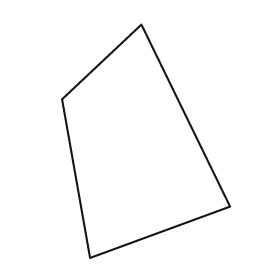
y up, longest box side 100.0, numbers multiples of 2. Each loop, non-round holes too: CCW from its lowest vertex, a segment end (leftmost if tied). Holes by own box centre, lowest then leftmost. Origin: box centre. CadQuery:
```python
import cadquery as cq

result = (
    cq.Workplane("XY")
    .moveTo(-24.0, -50.0)
    .lineTo(36.0, -28.0)
    .lineTo(-2.0, 50.0)
    .lineTo(-36.0, 18.0)
    .close()
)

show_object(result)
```